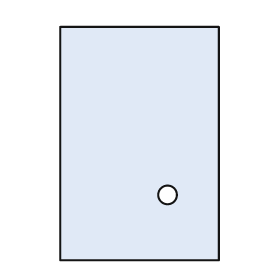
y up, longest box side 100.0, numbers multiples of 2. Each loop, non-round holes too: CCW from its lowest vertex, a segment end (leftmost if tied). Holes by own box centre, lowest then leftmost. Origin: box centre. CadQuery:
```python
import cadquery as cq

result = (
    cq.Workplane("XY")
    .moveTo(-34.0, -50.0)
    .lineTo(34.0, -50.0)
    .lineTo(34.0, 50.0)
    .lineTo(-34.0, 50.0)
    .close()
    .moveTo(12.0, -22.0)
    .circle(4.0)
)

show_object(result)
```